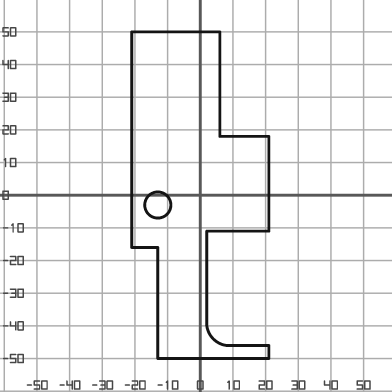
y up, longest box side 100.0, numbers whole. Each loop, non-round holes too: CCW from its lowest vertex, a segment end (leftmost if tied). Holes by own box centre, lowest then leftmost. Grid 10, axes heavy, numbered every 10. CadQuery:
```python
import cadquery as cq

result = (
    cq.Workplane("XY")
    .moveTo(-13.0, -50.0)
    .lineTo(21.0, -50.0)
    .lineTo(21.0, -46.0)
    .lineTo(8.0, -46.0)
    .threePointArc((4.0, -44.0), (2.0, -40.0))
    .lineTo(2.0, -11.0)
    .lineTo(21.0, -11.0)
    .lineTo(21.0, 18.0)
    .lineTo(6.0, 18.0)
    .lineTo(6.0, 50.0)
    .lineTo(-21.0, 50.0)
    .lineTo(-21.0, -16.0)
    .lineTo(-13.0, -16.0)
    .close()
    .moveTo(-13.0, -3.0)
    .circle(4.0)
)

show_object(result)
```